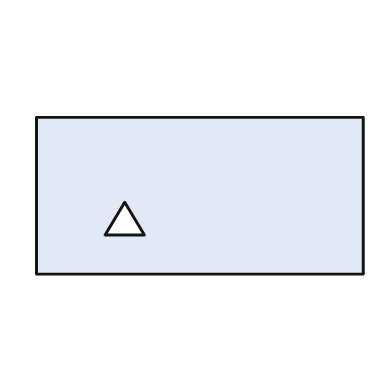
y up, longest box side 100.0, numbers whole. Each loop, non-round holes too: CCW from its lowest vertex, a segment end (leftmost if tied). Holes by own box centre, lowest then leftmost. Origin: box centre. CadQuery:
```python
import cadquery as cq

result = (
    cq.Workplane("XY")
    .moveTo(-50.0, -24.0)
    .lineTo(50.0, -24.0)
    .lineTo(50.0, 24.0)
    .lineTo(-50.0, 24.0)
    .close()
    .moveTo(-29.0, -12.0)
    .lineTo(-17.0, -12.0)
    .lineTo(-23.0, -2.0)
    .close()
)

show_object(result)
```